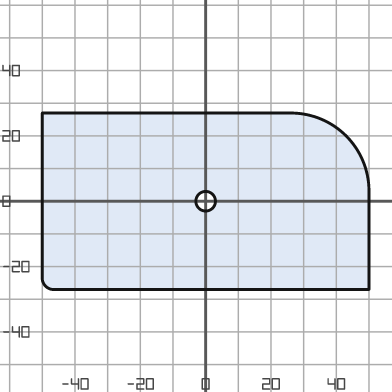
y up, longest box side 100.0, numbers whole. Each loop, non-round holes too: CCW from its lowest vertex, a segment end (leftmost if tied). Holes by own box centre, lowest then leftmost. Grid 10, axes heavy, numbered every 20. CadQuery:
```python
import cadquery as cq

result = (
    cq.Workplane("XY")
    .moveTo(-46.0, -27.0)
    .lineTo(50.0, -27.0)
    .lineTo(50.0, 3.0)
    .threePointArc((43.0, 20.0), (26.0, 27.0))
    .lineTo(-50.0, 27.0)
    .lineTo(-50.0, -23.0)
    .threePointArc((-49.0, -26.0), (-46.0, -27.0))
    .close()
    .moveTo(0.0, 0.0)
    .circle(3.0)
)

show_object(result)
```